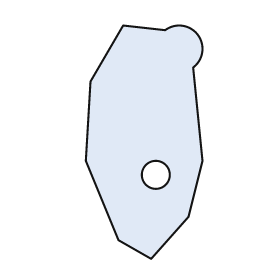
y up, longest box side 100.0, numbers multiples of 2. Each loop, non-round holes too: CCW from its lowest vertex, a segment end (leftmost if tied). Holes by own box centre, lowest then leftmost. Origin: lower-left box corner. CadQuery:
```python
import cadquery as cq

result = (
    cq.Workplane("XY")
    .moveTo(28.0, 0.0)
    .lineTo(44.0, 18.0)
    .lineTo(50.0, 42.0)
    .lineTo(46.0, 82.0)
    .threePointArc((48.0, 96.0), (34.0, 98.0))
    .lineTo(16.0, 100.0)
    .lineTo(2.0, 76.0)
    .lineTo(0.0, 42.0)
    .lineTo(14.0, 8.0)
    .close()
    .moveTo(30.0, 36.0)
    .circle(6.0)
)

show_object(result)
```